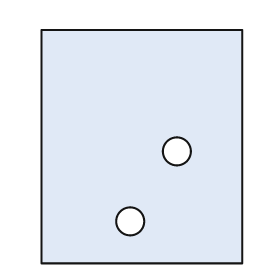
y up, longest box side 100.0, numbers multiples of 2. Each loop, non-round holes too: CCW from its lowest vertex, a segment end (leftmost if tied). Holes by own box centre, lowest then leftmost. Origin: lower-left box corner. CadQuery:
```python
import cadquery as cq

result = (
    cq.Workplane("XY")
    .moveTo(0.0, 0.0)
    .lineTo(86.0, 0.0)
    .lineTo(86.0, 100.0)
    .lineTo(0.0, 100.0)
    .close()
    .moveTo(38.0, 18.0)
    .circle(6.0)
    .moveTo(58.0, 48.0)
    .circle(6.0)
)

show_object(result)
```